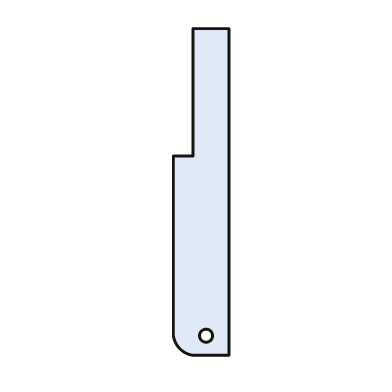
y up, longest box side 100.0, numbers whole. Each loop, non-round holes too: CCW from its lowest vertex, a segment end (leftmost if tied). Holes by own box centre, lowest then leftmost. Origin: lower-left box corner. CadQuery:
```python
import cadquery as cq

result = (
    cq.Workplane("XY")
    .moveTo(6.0, 0.0)
    .lineTo(17.0, 0.0)
    .lineTo(17.0, 100.0)
    .lineTo(6.0, 100.0)
    .lineTo(6.0, 61.0)
    .lineTo(0.0, 61.0)
    .lineTo(0.0, 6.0)
    .threePointArc((2.0, 2.0), (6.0, 0.0))
    .close()
    .moveTo(10.0, 6.0)
    .circle(2.0)
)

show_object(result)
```